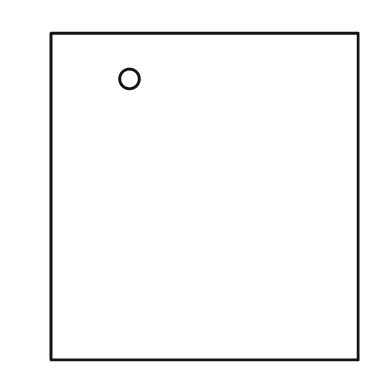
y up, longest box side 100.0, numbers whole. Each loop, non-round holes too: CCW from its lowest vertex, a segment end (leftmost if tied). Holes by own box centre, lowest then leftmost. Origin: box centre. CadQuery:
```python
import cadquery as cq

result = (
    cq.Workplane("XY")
    .moveTo(-47.0, -50.0)
    .lineTo(47.0, -50.0)
    .lineTo(47.0, 50.0)
    .lineTo(-47.0, 50.0)
    .close()
    .moveTo(-23.0, 36.0)
    .circle(3.0)
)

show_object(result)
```